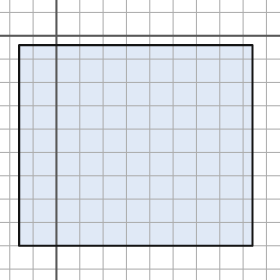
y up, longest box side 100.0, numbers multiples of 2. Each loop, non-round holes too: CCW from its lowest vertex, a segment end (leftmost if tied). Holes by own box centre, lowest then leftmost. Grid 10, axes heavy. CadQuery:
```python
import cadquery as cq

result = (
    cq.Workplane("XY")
    .moveTo(-16.0, -90.0)
    .lineTo(84.0, -90.0)
    .lineTo(84.0, -4.0)
    .lineTo(-16.0, -4.0)
    .close()
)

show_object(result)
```